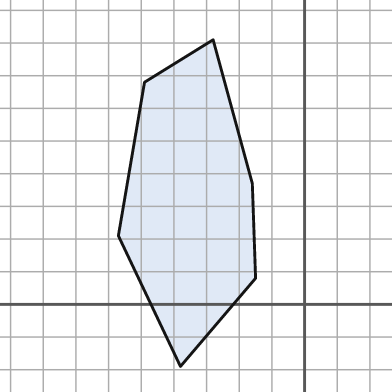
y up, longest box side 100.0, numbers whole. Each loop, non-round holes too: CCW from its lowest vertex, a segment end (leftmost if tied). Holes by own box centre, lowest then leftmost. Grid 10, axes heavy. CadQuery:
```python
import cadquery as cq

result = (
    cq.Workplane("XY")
    .moveTo(-38.0, -19.0)
    .lineTo(-15.0, 8.0)
    .lineTo(-16.0, 37.0)
    .lineTo(-28.0, 81.0)
    .lineTo(-49.0, 68.0)
    .lineTo(-57.0, 21.0)
    .close()
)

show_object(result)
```